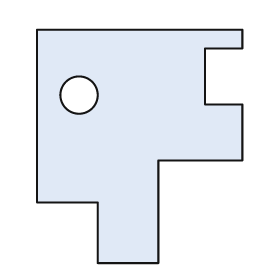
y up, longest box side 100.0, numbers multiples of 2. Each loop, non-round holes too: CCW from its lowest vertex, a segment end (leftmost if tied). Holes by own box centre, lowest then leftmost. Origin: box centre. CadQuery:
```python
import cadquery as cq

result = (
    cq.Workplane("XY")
    .moveTo(-18.0, -50.0)
    .lineTo(8.0, -50.0)
    .lineTo(8.0, -6.0)
    .lineTo(44.0, -6.0)
    .lineTo(44.0, 18.0)
    .lineTo(28.0, 18.0)
    .lineTo(28.0, 42.0)
    .lineTo(44.0, 42.0)
    .lineTo(44.0, 50.0)
    .lineTo(-44.0, 50.0)
    .lineTo(-44.0, -24.0)
    .lineTo(-18.0, -24.0)
    .close()
    .moveTo(-26.0, 22.0)
    .circle(8.0)
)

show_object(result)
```